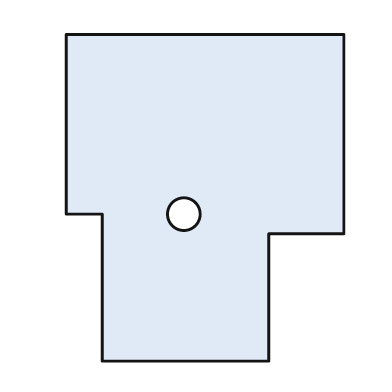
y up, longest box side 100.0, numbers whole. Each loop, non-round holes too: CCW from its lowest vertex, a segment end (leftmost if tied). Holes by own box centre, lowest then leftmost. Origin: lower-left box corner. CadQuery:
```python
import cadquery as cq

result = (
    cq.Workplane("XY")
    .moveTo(11.0, 0.0)
    .lineTo(62.0, 0.0)
    .lineTo(62.0, 39.0)
    .lineTo(85.0, 39.0)
    .lineTo(85.0, 100.0)
    .lineTo(0.0, 100.0)
    .lineTo(0.0, 45.0)
    .lineTo(11.0, 45.0)
    .close()
    .moveTo(36.0, 45.0)
    .circle(5.0)
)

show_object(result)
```